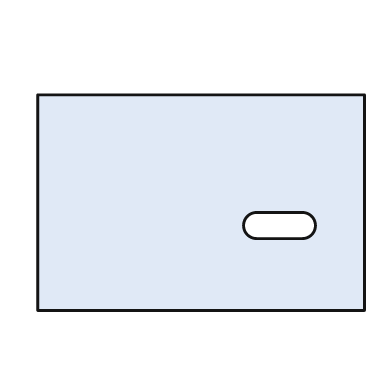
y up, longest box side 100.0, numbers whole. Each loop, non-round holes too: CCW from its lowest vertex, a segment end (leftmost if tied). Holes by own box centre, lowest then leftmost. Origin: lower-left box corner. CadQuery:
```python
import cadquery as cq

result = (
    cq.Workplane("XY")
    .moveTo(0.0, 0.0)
    .lineTo(100.0, 0.0)
    .lineTo(100.0, 66.0)
    .lineTo(0.0, 66.0)
    .close()
    .moveTo(67.0, 22.0)
    .lineTo(81.0, 22.0)
    .threePointArc((85.0, 26.0), (81.0, 30.0))
    .lineTo(67.0, 30.0)
    .threePointArc((63.0, 26.0), (67.0, 22.0))
    .close()
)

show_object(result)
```